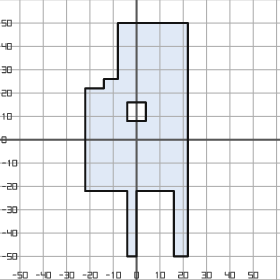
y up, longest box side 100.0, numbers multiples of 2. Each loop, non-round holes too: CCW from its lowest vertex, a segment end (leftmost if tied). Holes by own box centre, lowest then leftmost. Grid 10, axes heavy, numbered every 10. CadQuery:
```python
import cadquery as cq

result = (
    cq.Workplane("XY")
    .moveTo(-4.0, -50.0)
    .lineTo(0.0, -50.0)
    .lineTo(0.0, -22.0)
    .lineTo(16.0, -22.0)
    .lineTo(16.0, -50.0)
    .lineTo(22.0, -50.0)
    .lineTo(22.0, 50.0)
    .lineTo(-8.0, 50.0)
    .lineTo(-8.0, 26.0)
    .lineTo(-14.0, 26.0)
    .lineTo(-14.0, 22.0)
    .lineTo(-22.0, 22.0)
    .lineTo(-22.0, -22.0)
    .lineTo(-4.0, -22.0)
    .close()
    .moveTo(-4.0, 8.0)
    .lineTo(4.0, 8.0)
    .lineTo(4.0, 16.0)
    .lineTo(-4.0, 16.0)
    .close()
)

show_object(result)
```